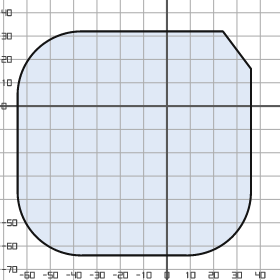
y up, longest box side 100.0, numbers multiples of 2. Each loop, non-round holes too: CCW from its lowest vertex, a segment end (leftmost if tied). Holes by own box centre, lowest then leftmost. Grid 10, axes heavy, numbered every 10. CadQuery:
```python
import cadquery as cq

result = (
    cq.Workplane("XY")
    .moveTo(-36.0, -64.0)
    .lineTo(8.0, -64.0)
    .threePointArc((28.0, -56.0), (36.0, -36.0))
    .lineTo(36.0, 16.0)
    .lineTo(24.0, 32.0)
    .lineTo(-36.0, 32.0)
    .threePointArc((-56.0, 24.0), (-64.0, 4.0))
    .lineTo(-64.0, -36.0)
    .threePointArc((-56.0, -56.0), (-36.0, -64.0))
    .close()
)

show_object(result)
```